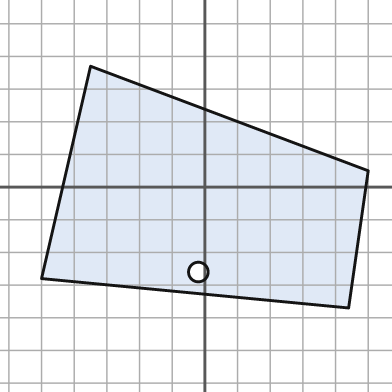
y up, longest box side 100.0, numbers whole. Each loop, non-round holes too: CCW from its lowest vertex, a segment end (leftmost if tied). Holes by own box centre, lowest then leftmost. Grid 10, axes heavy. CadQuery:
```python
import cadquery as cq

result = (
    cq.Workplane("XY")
    .moveTo(44.0, -37.0)
    .lineTo(50.0, 5.0)
    .lineTo(-35.0, 37.0)
    .lineTo(-50.0, -28.0)
    .close()
    .moveTo(-2.0, -26.0)
    .circle(3.0)
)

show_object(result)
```